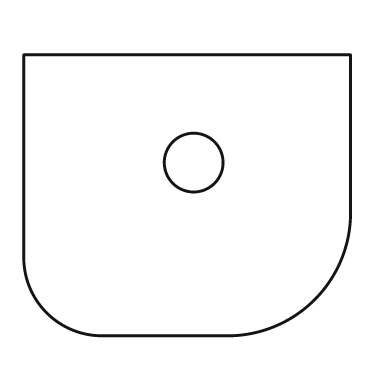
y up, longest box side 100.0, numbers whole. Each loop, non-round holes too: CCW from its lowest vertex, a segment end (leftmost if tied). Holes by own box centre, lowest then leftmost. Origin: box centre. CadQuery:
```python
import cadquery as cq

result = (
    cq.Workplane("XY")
    .moveTo(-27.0, -43.0)
    .lineTo(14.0, -43.0)
    .threePointArc((39.0, -32.0), (50.0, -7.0))
    .lineTo(50.0, 43.0)
    .lineTo(-50.0, 43.0)
    .lineTo(-50.0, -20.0)
    .threePointArc((-43.0, -36.0), (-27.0, -43.0))
    .close()
    .moveTo(2.0, 10.0)
    .circle(9.0)
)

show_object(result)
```